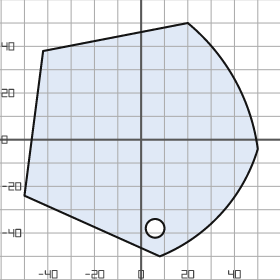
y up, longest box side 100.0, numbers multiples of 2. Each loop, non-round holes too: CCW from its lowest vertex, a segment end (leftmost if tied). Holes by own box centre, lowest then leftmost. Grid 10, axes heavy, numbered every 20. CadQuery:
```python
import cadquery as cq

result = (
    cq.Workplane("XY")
    .moveTo(8.0, -50.0)
    .threePointArc((34.0, -32.0), (50.0, -4.0))
    .threePointArc((40.0, 26.0), (20.0, 50.0))
    .lineTo(-42.0, 38.0)
    .lineTo(-50.0, -24.0)
    .close()
    .moveTo(6.0, -38.0)
    .circle(4.0)
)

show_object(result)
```